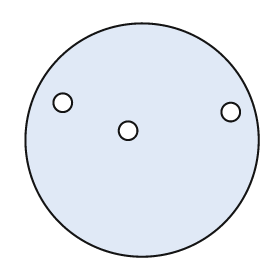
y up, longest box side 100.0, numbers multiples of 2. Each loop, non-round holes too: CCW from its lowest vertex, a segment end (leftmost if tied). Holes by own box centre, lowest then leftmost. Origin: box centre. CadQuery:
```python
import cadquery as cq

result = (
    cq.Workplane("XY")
    .moveTo(0.0, 0.0)
    .circle(50.0)
    .moveTo(-6.0, 4.0)
    .circle(4.0)
    .moveTo(38.0, 12.0)
    .circle(4.0)
    .moveTo(-34.0, 16.0)
    .circle(4.0)
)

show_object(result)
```